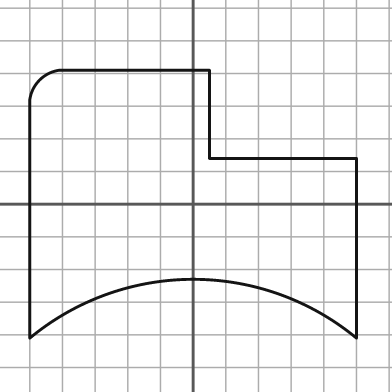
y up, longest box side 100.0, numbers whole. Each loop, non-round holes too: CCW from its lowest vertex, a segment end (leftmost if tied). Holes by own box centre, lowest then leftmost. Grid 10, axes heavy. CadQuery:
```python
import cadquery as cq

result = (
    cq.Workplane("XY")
    .moveTo(-50.0, -41.0)
    .threePointArc((0.0, -23.0), (50.0, -41.0))
    .lineTo(50.0, 14.0)
    .lineTo(5.0, 14.0)
    .lineTo(5.0, 41.0)
    .lineTo(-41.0, 41.0)
    .threePointArc((-47.0, 38.0), (-50.0, 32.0))
    .close()
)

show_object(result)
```